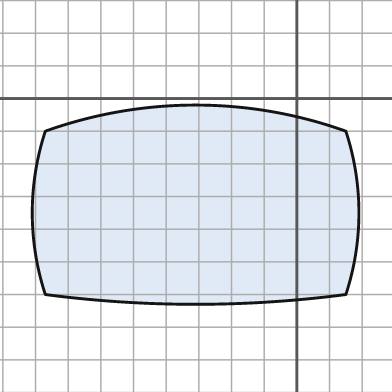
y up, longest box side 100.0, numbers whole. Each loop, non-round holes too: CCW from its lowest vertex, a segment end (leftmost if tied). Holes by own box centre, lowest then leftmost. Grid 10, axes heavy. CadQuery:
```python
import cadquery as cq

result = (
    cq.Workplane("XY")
    .moveTo(-77.0, -60.0)
    .threePointArc((-31.0, -63.0), (15.0, -60.0))
    .threePointArc((19.0, -35.0), (15.0, -10.0))
    .threePointArc((-31.0, -2.0), (-77.0, -10.0))
    .threePointArc((-81.0, -35.0), (-77.0, -60.0))
    .close()
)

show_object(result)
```